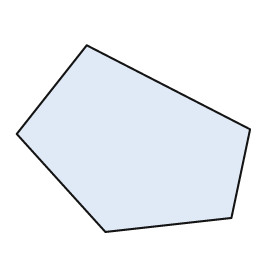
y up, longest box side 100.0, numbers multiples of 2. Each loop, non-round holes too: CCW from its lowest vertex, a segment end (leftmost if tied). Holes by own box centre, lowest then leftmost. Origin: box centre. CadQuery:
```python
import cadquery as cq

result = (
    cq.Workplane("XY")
    .moveTo(-12.0, -40.0)
    .lineTo(42.0, -34.0)
    .lineTo(50.0, 4.0)
    .lineTo(-20.0, 40.0)
    .lineTo(-50.0, 2.0)
    .close()
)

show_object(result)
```